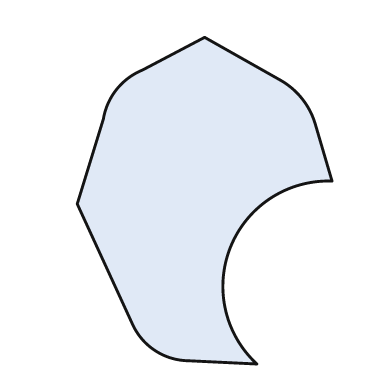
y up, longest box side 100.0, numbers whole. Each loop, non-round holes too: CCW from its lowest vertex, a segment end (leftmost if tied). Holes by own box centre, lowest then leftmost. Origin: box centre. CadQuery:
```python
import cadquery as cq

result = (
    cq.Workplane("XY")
    .moveTo(16.0, -50.0)
    .threePointArc((8.0, -14.0), (39.0, 6.0))
    .lineTo(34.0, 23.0)
    .threePointArc((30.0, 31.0), (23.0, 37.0))
    .lineTo(0.0, 50.0)
    .lineTo(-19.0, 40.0)
    .threePointArc((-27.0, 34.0), (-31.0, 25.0))
    .lineTo(-39.0, -1.0)
    .lineTo(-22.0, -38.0)
    .threePointArc((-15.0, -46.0), (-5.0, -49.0))
    .close()
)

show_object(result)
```